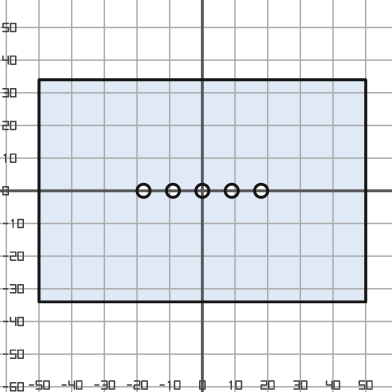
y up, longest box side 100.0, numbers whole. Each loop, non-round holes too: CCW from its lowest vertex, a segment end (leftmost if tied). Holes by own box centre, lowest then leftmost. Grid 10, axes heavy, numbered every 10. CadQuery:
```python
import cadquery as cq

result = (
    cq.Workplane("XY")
    .moveTo(-50.0, -34.0)
    .lineTo(50.0, -34.0)
    .lineTo(50.0, 34.0)
    .lineTo(-50.0, 34.0)
    .close()
    .moveTo(-18.0, 0.0)
    .circle(2.0)
    .moveTo(-9.0, 0.0)
    .circle(2.0)
    .moveTo(0.0, 0.0)
    .circle(2.0)
    .moveTo(9.0, 0.0)
    .circle(2.0)
    .moveTo(18.0, 0.0)
    .circle(2.0)
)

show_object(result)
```